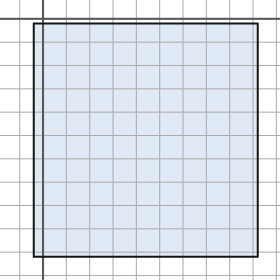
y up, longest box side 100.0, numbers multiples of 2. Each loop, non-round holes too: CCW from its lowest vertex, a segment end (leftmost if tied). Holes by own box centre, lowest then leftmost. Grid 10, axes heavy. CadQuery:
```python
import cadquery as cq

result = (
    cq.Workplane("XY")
    .moveTo(-4.0, -102.0)
    .lineTo(92.0, -102.0)
    .lineTo(92.0, -2.0)
    .lineTo(-4.0, -2.0)
    .close()
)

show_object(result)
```